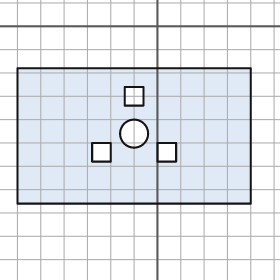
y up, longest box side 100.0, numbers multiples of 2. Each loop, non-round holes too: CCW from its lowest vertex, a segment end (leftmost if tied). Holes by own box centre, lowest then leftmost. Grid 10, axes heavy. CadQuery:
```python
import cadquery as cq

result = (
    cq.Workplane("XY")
    .moveTo(-60.0, -76.0)
    .lineTo(40.0, -76.0)
    .lineTo(40.0, -18.0)
    .lineTo(-60.0, -18.0)
    .close()
    .moveTo(-28.0, -58.0)
    .lineTo(-20.0, -58.0)
    .lineTo(-20.0, -50.0)
    .lineTo(-28.0, -50.0)
    .close()
    .moveTo(0.0, -58.0)
    .lineTo(8.0, -58.0)
    .lineTo(8.0, -50.0)
    .lineTo(0.0, -50.0)
    .close()
    .moveTo(-10.0, -46.0)
    .circle(6.0)
    .moveTo(-14.0, -34.0)
    .lineTo(-6.0, -34.0)
    .lineTo(-6.0, -26.0)
    .lineTo(-14.0, -26.0)
    .close()
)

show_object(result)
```